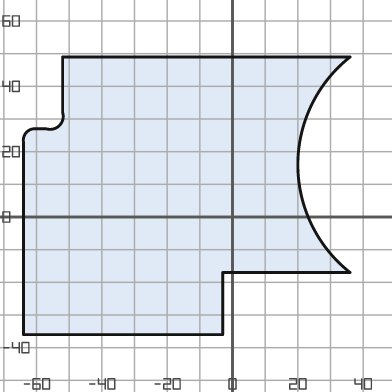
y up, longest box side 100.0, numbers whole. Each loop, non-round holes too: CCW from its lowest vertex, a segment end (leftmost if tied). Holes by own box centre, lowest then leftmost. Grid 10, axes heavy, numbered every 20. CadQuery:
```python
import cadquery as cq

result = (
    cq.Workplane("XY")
    .moveTo(-64.0, -36.0)
    .lineTo(-3.0, -36.0)
    .lineTo(-3.0, -17.0)
    .lineTo(36.0, -17.0)
    .threePointArc((20.0, 16.0), (36.0, 49.0))
    .lineTo(-52.0, 49.0)
    .lineTo(-52.0, 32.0)
    .threePointArc((-53.0, 28.0), (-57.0, 27.0))
    .lineTo(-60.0, 27.0)
    .threePointArc((-63.0, 26.0), (-64.0, 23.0))
    .close()
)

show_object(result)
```